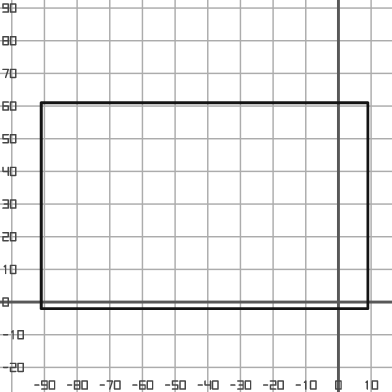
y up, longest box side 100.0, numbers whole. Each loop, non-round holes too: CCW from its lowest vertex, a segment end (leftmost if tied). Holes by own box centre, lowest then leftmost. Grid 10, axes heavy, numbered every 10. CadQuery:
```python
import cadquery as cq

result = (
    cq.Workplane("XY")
    .moveTo(-91.0, -2.0)
    .lineTo(9.0, -2.0)
    .lineTo(9.0, 61.0)
    .lineTo(-91.0, 61.0)
    .close()
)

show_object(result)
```